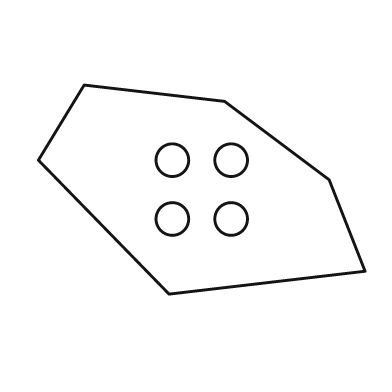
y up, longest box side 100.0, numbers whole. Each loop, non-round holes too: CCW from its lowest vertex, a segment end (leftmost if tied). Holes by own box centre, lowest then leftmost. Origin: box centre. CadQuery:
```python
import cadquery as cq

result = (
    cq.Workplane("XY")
    .moveTo(-10.0, -32.0)
    .lineTo(50.0, -25.0)
    .lineTo(39.0, 3.0)
    .lineTo(7.0, 27.0)
    .lineTo(-36.0, 32.0)
    .lineTo(-50.0, 9.0)
    .close()
    .moveTo(-9.0, -9.0)
    .circle(5.0)
    .moveTo(9.0, -9.0)
    .circle(5.0)
    .moveTo(-9.0, 9.0)
    .circle(5.0)
    .moveTo(9.0, 9.0)
    .circle(5.0)
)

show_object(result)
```